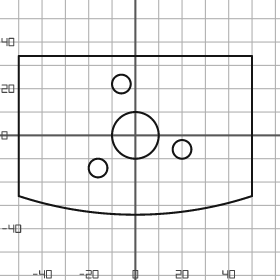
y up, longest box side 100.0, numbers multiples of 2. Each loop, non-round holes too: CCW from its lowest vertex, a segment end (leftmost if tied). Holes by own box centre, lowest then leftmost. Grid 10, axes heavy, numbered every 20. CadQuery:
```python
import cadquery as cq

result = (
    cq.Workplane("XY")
    .moveTo(-50.0, -26.0)
    .threePointArc((0.0, -34.0), (50.0, -26.0))
    .lineTo(50.0, 34.0)
    .lineTo(-50.0, 34.0)
    .close()
    .moveTo(-16.0, -14.0)
    .circle(4.0)
    .moveTo(20.0, -6.0)
    .circle(4.0)
    .moveTo(0.0, 0.0)
    .circle(10.0)
    .moveTo(-6.0, 22.0)
    .circle(4.0)
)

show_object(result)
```